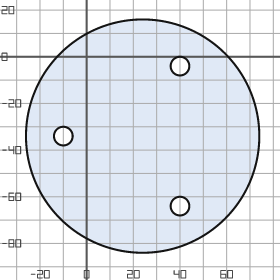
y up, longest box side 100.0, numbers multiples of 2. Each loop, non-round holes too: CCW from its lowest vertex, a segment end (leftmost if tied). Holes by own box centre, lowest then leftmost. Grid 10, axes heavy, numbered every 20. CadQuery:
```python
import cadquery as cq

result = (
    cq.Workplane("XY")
    .moveTo(24.0, -34.0)
    .circle(50.0)
    .moveTo(40.0, -64.0)
    .circle(4.0)
    .moveTo(-10.0, -34.0)
    .circle(4.0)
    .moveTo(40.0, -4.0)
    .circle(4.0)
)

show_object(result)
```